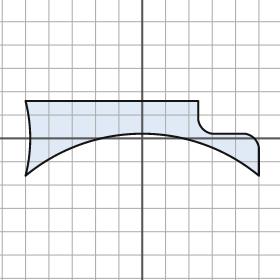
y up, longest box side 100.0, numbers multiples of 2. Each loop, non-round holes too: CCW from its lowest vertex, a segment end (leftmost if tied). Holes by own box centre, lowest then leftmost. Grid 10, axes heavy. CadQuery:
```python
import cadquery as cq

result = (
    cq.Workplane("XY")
    .moveTo(-50.0, -16.0)
    .threePointArc((0.0, 2.0), (50.0, -16.0))
    .lineTo(50.0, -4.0)
    .threePointArc((48.0, 0.0), (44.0, 2.0))
    .lineTo(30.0, 2.0)
    .threePointArc((26.0, 4.0), (24.0, 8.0))
    .lineTo(24.0, 16.0)
    .lineTo(-50.0, 16.0)
    .threePointArc((-48.0, 0.0), (-50.0, -16.0))
    .close()
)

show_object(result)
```